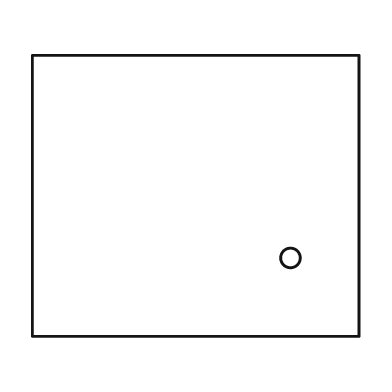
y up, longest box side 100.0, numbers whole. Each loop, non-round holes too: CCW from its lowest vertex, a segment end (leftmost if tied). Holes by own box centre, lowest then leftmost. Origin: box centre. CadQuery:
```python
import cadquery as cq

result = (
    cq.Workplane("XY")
    .moveTo(-50.0, -43.0)
    .lineTo(50.0, -43.0)
    .lineTo(50.0, 43.0)
    .lineTo(-50.0, 43.0)
    .close()
    .moveTo(29.0, -19.0)
    .circle(3.0)
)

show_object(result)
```